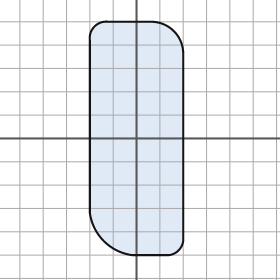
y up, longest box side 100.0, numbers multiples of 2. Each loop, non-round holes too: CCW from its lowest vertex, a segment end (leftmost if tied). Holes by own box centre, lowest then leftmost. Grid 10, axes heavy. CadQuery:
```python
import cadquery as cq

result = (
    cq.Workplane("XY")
    .moveTo(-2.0, -50.0)
    .lineTo(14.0, -50.0)
    .threePointArc((18.0, -48.0), (20.0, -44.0))
    .lineTo(20.0, 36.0)
    .threePointArc((16.0, 46.0), (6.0, 50.0))
    .lineTo(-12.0, 50.0)
    .threePointArc((-18.0, 48.0), (-20.0, 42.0))
    .lineTo(-20.0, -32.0)
    .threePointArc((-14.0, -44.0), (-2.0, -50.0))
    .close()
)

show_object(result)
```